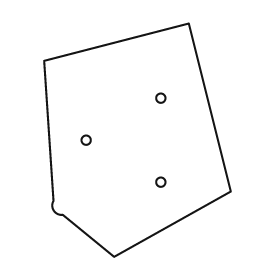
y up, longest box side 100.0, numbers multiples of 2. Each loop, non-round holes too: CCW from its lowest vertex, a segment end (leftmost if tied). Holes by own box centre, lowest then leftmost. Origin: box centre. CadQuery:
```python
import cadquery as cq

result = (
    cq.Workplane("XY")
    .moveTo(-10.0, -50.0)
    .lineTo(40.0, -22.0)
    .lineTo(22.0, 50.0)
    .lineTo(-40.0, 34.0)
    .lineTo(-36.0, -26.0)
    .threePointArc((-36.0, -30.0), (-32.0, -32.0))
    .close()
    .moveTo(10.0, -18.0)
    .circle(2.0)
    .moveTo(-22.0, 0.0)
    .circle(2.0)
    .moveTo(10.0, 18.0)
    .circle(2.0)
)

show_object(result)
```